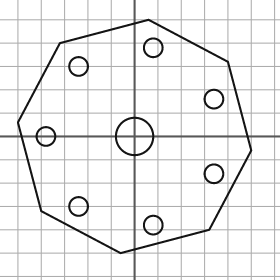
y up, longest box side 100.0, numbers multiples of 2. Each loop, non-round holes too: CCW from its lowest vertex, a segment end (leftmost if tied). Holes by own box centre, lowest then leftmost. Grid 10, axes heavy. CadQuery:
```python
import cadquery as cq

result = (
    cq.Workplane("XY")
    .moveTo(-6.0, -50.0)
    .lineTo(32.0, -40.0)
    .lineTo(50.0, -6.0)
    .lineTo(40.0, 32.0)
    .lineTo(6.0, 50.0)
    .lineTo(-32.0, 40.0)
    .lineTo(-50.0, 6.0)
    .lineTo(-40.0, -32.0)
    .close()
    .moveTo(8.0, -38.0)
    .circle(4.0)
    .moveTo(-24.0, -30.0)
    .circle(4.0)
    .moveTo(34.0, -16.0)
    .circle(4.0)
    .moveTo(-38.0, 0.0)
    .circle(4.0)
    .moveTo(0.0, 0.0)
    .circle(8.0)
    .moveTo(34.0, 16.0)
    .circle(4.0)
    .moveTo(-24.0, 30.0)
    .circle(4.0)
    .moveTo(8.0, 38.0)
    .circle(4.0)
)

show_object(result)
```